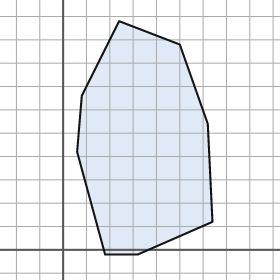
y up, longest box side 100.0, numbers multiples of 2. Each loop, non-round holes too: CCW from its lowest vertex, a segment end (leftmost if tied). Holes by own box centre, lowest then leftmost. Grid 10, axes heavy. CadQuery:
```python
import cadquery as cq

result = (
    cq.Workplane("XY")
    .moveTo(18.0, -2.0)
    .lineTo(32.0, -2.0)
    .lineTo(64.0, 12.0)
    .lineTo(62.0, 54.0)
    .lineTo(50.0, 88.0)
    .lineTo(24.0, 98.0)
    .lineTo(8.0, 66.0)
    .lineTo(6.0, 42.0)
    .close()
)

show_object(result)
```